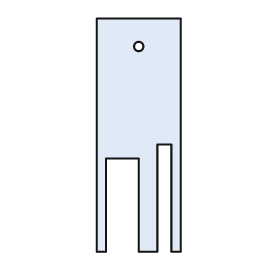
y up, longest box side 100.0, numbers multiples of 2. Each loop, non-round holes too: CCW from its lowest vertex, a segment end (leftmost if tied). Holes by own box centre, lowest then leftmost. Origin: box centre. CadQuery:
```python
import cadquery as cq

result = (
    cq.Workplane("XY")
    .moveTo(-18.0, -50.0)
    .lineTo(-14.0, -50.0)
    .lineTo(-14.0, -10.0)
    .lineTo(0.0, -10.0)
    .lineTo(0.0, -50.0)
    .lineTo(8.0, -50.0)
    .lineTo(8.0, -4.0)
    .lineTo(14.0, -4.0)
    .lineTo(14.0, -50.0)
    .lineTo(18.0, -50.0)
    .lineTo(18.0, 50.0)
    .lineTo(-18.0, 50.0)
    .close()
    .moveTo(0.0, 38.0)
    .circle(2.0)
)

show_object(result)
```